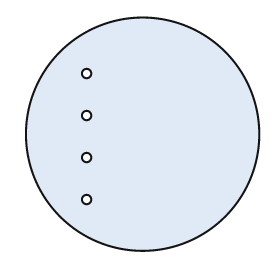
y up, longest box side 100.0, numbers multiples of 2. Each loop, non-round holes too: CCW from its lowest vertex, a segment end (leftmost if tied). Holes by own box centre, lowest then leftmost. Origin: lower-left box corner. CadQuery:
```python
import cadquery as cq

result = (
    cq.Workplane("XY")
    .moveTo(50.0, 50.0)
    .circle(50.0)
    .moveTo(26.0, 22.0)
    .circle(2.0)
    .moveTo(26.0, 40.0)
    .circle(2.0)
    .moveTo(26.0, 58.0)
    .circle(2.0)
    .moveTo(26.0, 76.0)
    .circle(2.0)
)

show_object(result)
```